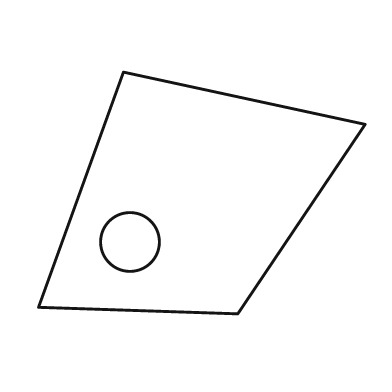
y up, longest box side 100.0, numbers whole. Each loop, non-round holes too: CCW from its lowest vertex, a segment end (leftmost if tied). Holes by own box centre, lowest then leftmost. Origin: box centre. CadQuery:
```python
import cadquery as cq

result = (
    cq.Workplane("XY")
    .moveTo(11.0, -37.0)
    .lineTo(50.0, 21.0)
    .lineTo(-24.0, 37.0)
    .lineTo(-50.0, -35.0)
    .close()
    .moveTo(-22.0, -15.0)
    .circle(9.0)
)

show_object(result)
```